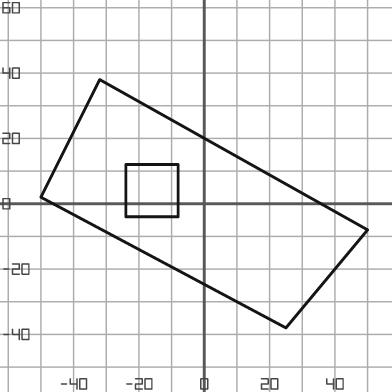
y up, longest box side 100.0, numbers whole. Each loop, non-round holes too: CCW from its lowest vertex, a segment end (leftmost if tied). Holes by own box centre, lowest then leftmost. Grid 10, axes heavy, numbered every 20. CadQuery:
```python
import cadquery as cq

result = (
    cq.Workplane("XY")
    .moveTo(25.0, -38.0)
    .lineTo(50.0, -8.0)
    .lineTo(-32.0, 38.0)
    .lineTo(-50.0, 2.0)
    .close()
    .moveTo(-24.0, -4.0)
    .lineTo(-8.0, -4.0)
    .lineTo(-8.0, 12.0)
    .lineTo(-24.0, 12.0)
    .close()
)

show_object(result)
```